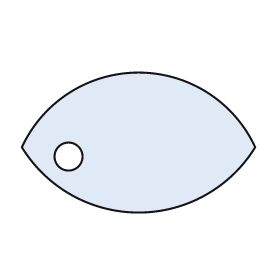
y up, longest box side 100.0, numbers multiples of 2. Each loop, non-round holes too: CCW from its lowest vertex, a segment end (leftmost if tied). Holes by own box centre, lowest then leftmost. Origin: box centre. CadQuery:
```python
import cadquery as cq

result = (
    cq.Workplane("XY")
    .moveTo(-50.0, -2.0)
    .threePointArc((0.0, -30.0), (50.0, -2.0))
    .threePointArc((0.0, 30.0), (-50.0, -2.0))
    .close()
    .moveTo(-30.0, -6.0)
    .circle(6.0)
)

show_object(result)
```